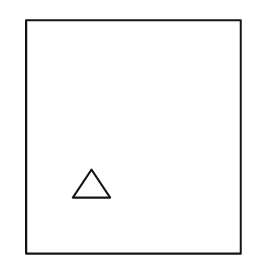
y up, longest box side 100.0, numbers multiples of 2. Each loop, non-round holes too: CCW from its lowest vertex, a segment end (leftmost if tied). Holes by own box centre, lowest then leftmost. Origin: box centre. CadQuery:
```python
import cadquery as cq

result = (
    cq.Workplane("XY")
    .moveTo(-46.0, -50.0)
    .lineTo(46.0, -50.0)
    .lineTo(46.0, 50.0)
    .lineTo(-46.0, 50.0)
    .close()
    .moveTo(-26.0, -26.0)
    .lineTo(-10.0, -26.0)
    .lineTo(-18.0, -14.0)
    .close()
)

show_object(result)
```